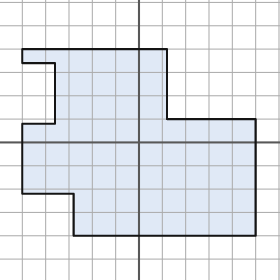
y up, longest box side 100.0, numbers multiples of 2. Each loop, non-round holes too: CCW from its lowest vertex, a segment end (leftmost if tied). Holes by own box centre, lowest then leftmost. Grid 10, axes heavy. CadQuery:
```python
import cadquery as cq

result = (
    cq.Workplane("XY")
    .moveTo(-28.0, -40.0)
    .lineTo(50.0, -40.0)
    .lineTo(50.0, 10.0)
    .lineTo(12.0, 10.0)
    .lineTo(12.0, 40.0)
    .lineTo(-50.0, 40.0)
    .lineTo(-50.0, 34.0)
    .lineTo(-36.0, 34.0)
    .lineTo(-36.0, 8.0)
    .lineTo(-50.0, 8.0)
    .lineTo(-50.0, -22.0)
    .lineTo(-28.0, -22.0)
    .close()
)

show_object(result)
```